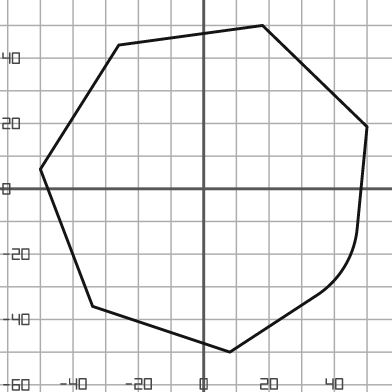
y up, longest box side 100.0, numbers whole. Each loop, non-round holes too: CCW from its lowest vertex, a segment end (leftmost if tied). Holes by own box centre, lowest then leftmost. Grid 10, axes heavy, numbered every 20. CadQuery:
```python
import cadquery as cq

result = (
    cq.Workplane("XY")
    .moveTo(8.0, -50.0)
    .lineTo(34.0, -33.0)
    .threePointArc((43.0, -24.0), (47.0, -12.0))
    .lineTo(50.0, 19.0)
    .lineTo(18.0, 50.0)
    .lineTo(-26.0, 44.0)
    .lineTo(-50.0, 6.0)
    .lineTo(-34.0, -36.0)
    .close()
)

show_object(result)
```